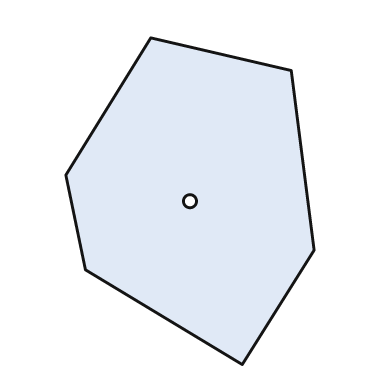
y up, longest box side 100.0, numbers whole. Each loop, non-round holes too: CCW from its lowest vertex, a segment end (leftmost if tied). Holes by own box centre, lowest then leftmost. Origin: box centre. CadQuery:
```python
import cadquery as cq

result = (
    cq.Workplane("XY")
    .moveTo(16.0, -50.0)
    .lineTo(38.0, -15.0)
    .lineTo(31.0, 40.0)
    .lineTo(-12.0, 50.0)
    .lineTo(-38.0, 8.0)
    .lineTo(-32.0, -21.0)
    .close()
    .moveTo(0.0, 0.0)
    .circle(2.0)
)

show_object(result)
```